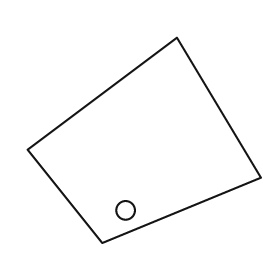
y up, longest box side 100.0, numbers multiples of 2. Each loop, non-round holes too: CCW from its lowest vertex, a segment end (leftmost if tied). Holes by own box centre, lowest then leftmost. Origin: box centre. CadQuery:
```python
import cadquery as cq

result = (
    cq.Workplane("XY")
    .moveTo(-18.0, -44.0)
    .lineTo(50.0, -16.0)
    .lineTo(14.0, 44.0)
    .lineTo(-50.0, -4.0)
    .close()
    .moveTo(-8.0, -30.0)
    .circle(4.0)
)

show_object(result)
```